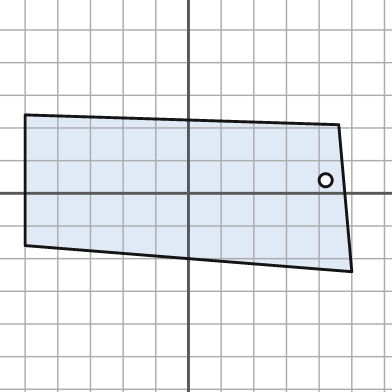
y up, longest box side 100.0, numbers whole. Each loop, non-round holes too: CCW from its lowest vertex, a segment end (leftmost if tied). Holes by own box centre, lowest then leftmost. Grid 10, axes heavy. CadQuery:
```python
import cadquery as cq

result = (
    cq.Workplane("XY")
    .moveTo(50.0, -24.0)
    .lineTo(46.0, 21.0)
    .lineTo(-50.0, 24.0)
    .lineTo(-50.0, -16.0)
    .close()
    .moveTo(42.0, 4.0)
    .circle(2.0)
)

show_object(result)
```